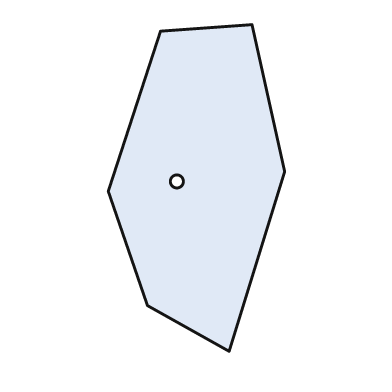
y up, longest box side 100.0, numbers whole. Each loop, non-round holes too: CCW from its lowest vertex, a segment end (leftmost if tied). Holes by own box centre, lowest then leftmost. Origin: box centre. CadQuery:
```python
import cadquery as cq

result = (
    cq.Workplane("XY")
    .moveTo(10.0, -50.0)
    .lineTo(27.0, 5.0)
    .lineTo(17.0, 50.0)
    .lineTo(-11.0, 48.0)
    .lineTo(-27.0, -1.0)
    .lineTo(-15.0, -36.0)
    .close()
    .moveTo(-6.0, 2.0)
    .circle(2.0)
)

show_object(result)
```